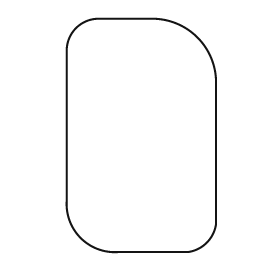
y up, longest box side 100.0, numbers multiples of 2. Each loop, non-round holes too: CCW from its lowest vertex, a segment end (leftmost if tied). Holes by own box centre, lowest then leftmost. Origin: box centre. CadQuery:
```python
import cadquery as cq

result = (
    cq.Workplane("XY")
    .moveTo(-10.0, -50.0)
    .lineTo(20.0, -50.0)
    .threePointArc((28.0, -46.0), (32.0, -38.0))
    .lineTo(32.0, 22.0)
    .threePointArc((24.0, 42.0), (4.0, 50.0))
    .lineTo(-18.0, 50.0)
    .threePointArc((-28.0, 46.0), (-32.0, 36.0))
    .lineTo(-32.0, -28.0)
    .threePointArc((-26.0, -44.0), (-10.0, -50.0))
    .close()
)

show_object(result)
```